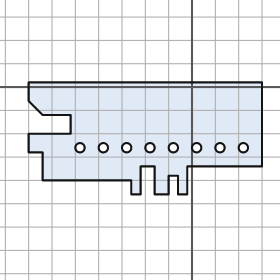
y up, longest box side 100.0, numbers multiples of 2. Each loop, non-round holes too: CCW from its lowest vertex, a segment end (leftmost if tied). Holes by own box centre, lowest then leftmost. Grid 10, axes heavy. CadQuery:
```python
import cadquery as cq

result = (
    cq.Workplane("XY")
    .moveTo(-26.0, -46.0)
    .lineTo(-22.0, -46.0)
    .lineTo(-22.0, -34.0)
    .lineTo(-16.0, -34.0)
    .lineTo(-16.0, -46.0)
    .lineTo(-10.0, -46.0)
    .lineTo(-10.0, -38.0)
    .lineTo(-6.0, -38.0)
    .lineTo(-6.0, -46.0)
    .lineTo(-2.0, -46.0)
    .lineTo(-2.0, -34.0)
    .lineTo(30.0, -34.0)
    .lineTo(30.0, 2.0)
    .lineTo(-70.0, 2.0)
    .lineTo(-70.0, -6.0)
    .lineTo(-64.0, -12.0)
    .lineTo(-52.0, -12.0)
    .lineTo(-52.0, -20.0)
    .lineTo(-70.0, -20.0)
    .lineTo(-70.0, -28.0)
    .lineTo(-64.0, -28.0)
    .lineTo(-64.0, -40.0)
    .lineTo(-26.0, -40.0)
    .close()
    .moveTo(-48.0, -26.0)
    .circle(2.0)
    .moveTo(-38.0, -26.0)
    .circle(2.0)
    .moveTo(-28.0, -26.0)
    .circle(2.0)
    .moveTo(-18.0, -26.0)
    .circle(2.0)
    .moveTo(-8.0, -26.0)
    .circle(2.0)
    .moveTo(2.0, -26.0)
    .circle(2.0)
    .moveTo(12.0, -26.0)
    .circle(2.0)
    .moveTo(22.0, -26.0)
    .circle(2.0)
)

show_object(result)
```